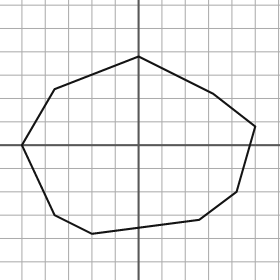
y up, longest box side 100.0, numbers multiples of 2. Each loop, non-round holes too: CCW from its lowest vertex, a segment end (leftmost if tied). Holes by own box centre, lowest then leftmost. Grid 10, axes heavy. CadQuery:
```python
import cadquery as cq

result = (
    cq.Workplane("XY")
    .moveTo(-20.0, -38.0)
    .lineTo(26.0, -32.0)
    .lineTo(42.0, -20.0)
    .lineTo(50.0, 8.0)
    .lineTo(32.0, 22.0)
    .lineTo(0.0, 38.0)
    .lineTo(-36.0, 24.0)
    .lineTo(-50.0, 0.0)
    .lineTo(-36.0, -30.0)
    .close()
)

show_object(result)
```